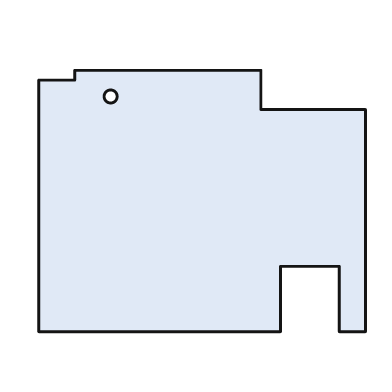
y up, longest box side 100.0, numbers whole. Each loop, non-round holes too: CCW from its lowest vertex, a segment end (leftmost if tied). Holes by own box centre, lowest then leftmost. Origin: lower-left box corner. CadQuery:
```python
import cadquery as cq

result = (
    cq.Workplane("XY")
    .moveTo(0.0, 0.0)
    .lineTo(74.0, 0.0)
    .lineTo(74.0, 20.0)
    .lineTo(92.0, 20.0)
    .lineTo(92.0, 0.0)
    .lineTo(100.0, 0.0)
    .lineTo(100.0, 68.0)
    .lineTo(68.0, 68.0)
    .lineTo(68.0, 80.0)
    .lineTo(11.0, 80.0)
    .lineTo(11.0, 77.0)
    .lineTo(0.0, 77.0)
    .close()
    .moveTo(22.0, 72.0)
    .circle(2.0)
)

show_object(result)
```